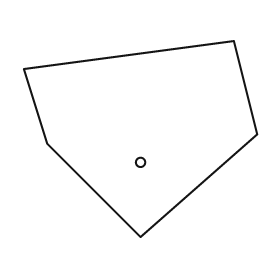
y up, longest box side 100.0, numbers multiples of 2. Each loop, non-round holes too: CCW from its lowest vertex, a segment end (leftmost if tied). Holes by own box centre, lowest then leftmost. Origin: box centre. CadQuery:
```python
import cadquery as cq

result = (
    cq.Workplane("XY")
    .moveTo(0.0, -42.0)
    .lineTo(50.0, 2.0)
    .lineTo(40.0, 42.0)
    .lineTo(-50.0, 30.0)
    .lineTo(-40.0, -2.0)
    .close()
    .moveTo(0.0, -10.0)
    .circle(2.0)
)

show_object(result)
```